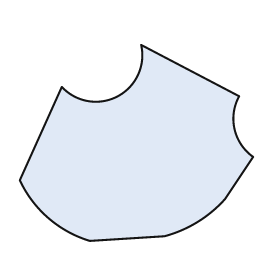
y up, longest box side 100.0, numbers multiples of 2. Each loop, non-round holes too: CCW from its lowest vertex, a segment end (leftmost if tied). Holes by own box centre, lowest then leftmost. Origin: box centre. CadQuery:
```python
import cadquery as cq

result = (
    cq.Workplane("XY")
    .moveTo(-20.0, -42.0)
    .lineTo(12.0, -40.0)
    .threePointArc((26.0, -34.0), (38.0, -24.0))
    .lineTo(50.0, -6.0)
    .threePointArc((42.0, 6.0), (44.0, 20.0))
    .lineTo(2.0, 42.0)
    .threePointArc((-8.0, 20.0), (-32.0, 24.0))
    .lineTo(-50.0, -16.0)
    .threePointArc((-38.0, -32.0), (-20.0, -42.0))
    .close()
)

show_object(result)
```